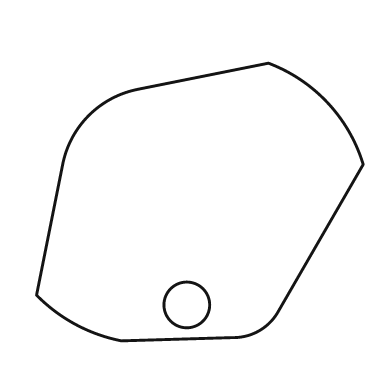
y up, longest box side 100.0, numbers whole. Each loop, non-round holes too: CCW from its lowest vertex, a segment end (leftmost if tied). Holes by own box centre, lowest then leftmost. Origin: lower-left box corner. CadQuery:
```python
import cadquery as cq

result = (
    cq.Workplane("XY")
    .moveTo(26.0, 0.0)
    .lineTo(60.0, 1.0)
    .threePointArc((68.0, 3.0), (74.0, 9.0))
    .lineTo(100.0, 54.0)
    .threePointArc((89.0, 73.0), (71.0, 85.0))
    .lineTo(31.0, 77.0)
    .threePointArc((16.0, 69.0), (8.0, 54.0))
    .lineTo(0.0, 14.0)
    .threePointArc((12.0, 5.0), (26.0, 0.0))
    .close()
    .moveTo(46.0, 11.0)
    .circle(7.0)
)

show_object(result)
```